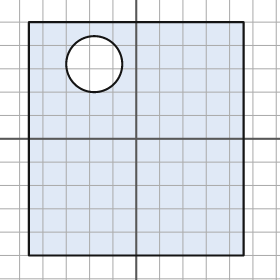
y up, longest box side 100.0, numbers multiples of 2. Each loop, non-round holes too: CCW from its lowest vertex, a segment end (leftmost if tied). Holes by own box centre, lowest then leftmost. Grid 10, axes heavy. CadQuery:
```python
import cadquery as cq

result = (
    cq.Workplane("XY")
    .moveTo(-46.0, -50.0)
    .lineTo(46.0, -50.0)
    .lineTo(46.0, 50.0)
    .lineTo(-46.0, 50.0)
    .close()
    .moveTo(-18.0, 32.0)
    .circle(12.0)
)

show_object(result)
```